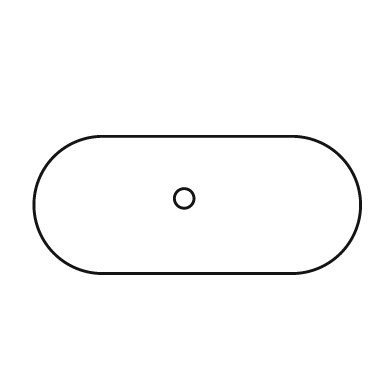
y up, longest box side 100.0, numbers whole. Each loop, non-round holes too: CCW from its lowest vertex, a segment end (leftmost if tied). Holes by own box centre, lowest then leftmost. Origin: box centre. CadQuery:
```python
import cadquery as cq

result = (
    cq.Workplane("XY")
    .moveTo(-29.0, -21.0)
    .lineTo(29.0, -21.0)
    .threePointArc((50.0, 0.0), (29.0, 21.0))
    .lineTo(-29.0, 21.0)
    .threePointArc((-50.0, 0.0), (-29.0, -21.0))
    .close()
    .moveTo(-4.0, 2.0)
    .circle(3.0)
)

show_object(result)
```